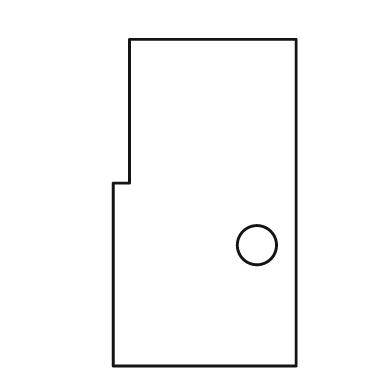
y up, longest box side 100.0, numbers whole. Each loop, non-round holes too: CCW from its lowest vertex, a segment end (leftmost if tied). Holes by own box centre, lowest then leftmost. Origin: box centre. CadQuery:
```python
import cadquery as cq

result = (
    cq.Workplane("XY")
    .moveTo(-28.0, -50.0)
    .lineTo(28.0, -50.0)
    .lineTo(28.0, 50.0)
    .lineTo(-23.0, 50.0)
    .lineTo(-23.0, 6.0)
    .lineTo(-28.0, 6.0)
    .close()
    .moveTo(16.0, -13.0)
    .circle(6.0)
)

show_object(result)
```